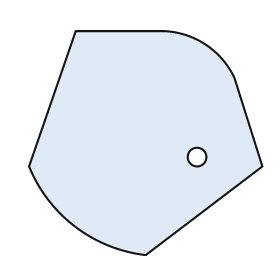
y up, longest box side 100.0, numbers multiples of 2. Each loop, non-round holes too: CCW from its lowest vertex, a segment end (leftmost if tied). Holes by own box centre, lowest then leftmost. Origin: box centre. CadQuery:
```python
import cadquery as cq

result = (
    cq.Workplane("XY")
    .moveTo(0.0, -48.0)
    .lineTo(50.0, -10.0)
    .lineTo(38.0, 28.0)
    .threePointArc((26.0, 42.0), (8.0, 48.0))
    .lineTo(-30.0, 48.0)
    .lineTo(-50.0, -10.0)
    .threePointArc((-30.0, -36.0), (0.0, -48.0))
    .close()
    .moveTo(22.0, -6.0)
    .circle(4.0)
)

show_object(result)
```